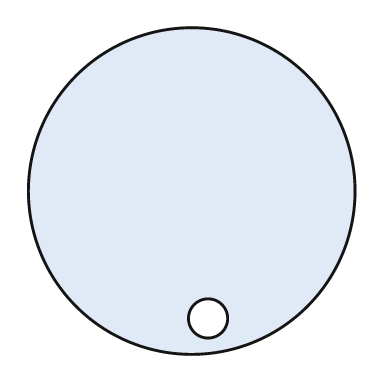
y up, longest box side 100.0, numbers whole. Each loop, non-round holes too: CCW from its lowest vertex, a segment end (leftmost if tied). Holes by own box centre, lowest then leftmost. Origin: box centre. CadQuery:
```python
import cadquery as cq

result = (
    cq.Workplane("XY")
    .moveTo(0.0, 0.0)
    .circle(50.0)
    .moveTo(5.0, -39.0)
    .circle(6.0)
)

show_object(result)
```